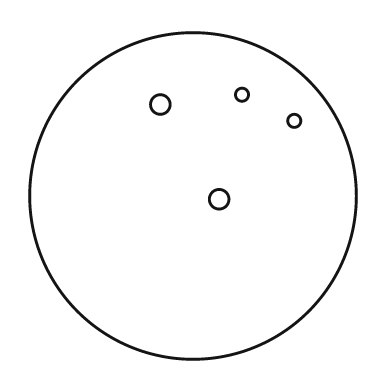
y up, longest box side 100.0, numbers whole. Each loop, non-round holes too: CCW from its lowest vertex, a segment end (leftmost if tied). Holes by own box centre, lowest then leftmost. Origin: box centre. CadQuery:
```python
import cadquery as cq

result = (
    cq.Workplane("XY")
    .moveTo(0.0, 0.0)
    .circle(50.0)
    .moveTo(8.0, -1.0)
    .circle(3.0)
    .moveTo(31.0, 23.0)
    .circle(2.0)
    .moveTo(-10.0, 28.0)
    .circle(3.0)
    .moveTo(15.0, 31.0)
    .circle(2.0)
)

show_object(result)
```